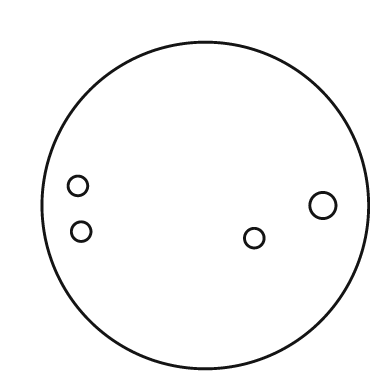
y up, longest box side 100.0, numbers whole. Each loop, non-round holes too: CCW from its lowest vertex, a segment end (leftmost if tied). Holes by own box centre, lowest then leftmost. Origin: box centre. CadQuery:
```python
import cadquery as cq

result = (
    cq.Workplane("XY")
    .moveTo(0.0, 0.0)
    .circle(50.0)
    .moveTo(15.0, -10.0)
    .circle(3.0)
    .moveTo(-38.0, -8.0)
    .circle(3.0)
    .moveTo(36.0, 0.0)
    .circle(4.0)
    .moveTo(-39.0, 6.0)
    .circle(3.0)
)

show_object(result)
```